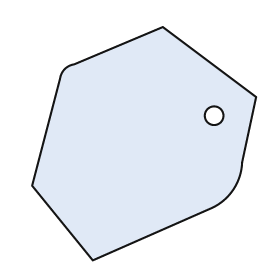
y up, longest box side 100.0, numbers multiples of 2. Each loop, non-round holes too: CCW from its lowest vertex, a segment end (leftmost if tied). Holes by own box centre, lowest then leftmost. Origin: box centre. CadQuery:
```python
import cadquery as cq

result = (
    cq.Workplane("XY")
    .moveTo(-22.0, -50.0)
    .lineTo(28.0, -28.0)
    .threePointArc((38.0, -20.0), (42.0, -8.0))
    .lineTo(48.0, 20.0)
    .lineTo(8.0, 50.0)
    .lineTo(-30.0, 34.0)
    .threePointArc((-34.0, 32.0), (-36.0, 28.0))
    .lineTo(-48.0, -18.0)
    .close()
    .moveTo(30.0, 12.0)
    .circle(4.0)
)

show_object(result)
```